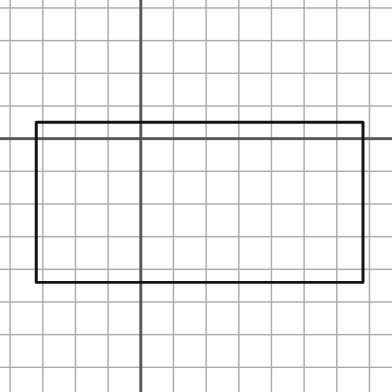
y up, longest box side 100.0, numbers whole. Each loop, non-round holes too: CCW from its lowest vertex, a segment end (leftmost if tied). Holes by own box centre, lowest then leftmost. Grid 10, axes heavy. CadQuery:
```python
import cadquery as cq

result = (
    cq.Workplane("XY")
    .moveTo(-32.0, -44.0)
    .lineTo(68.0, -44.0)
    .lineTo(68.0, 5.0)
    .lineTo(-32.0, 5.0)
    .close()
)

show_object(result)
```